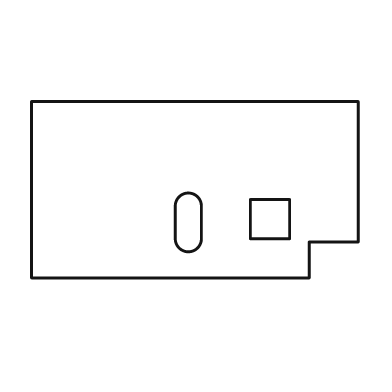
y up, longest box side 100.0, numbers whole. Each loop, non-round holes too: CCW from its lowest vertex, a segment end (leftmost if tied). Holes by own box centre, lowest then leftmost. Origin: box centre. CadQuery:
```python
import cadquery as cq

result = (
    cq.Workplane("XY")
    .moveTo(-50.0, -27.0)
    .lineTo(35.0, -27.0)
    .lineTo(35.0, -16.0)
    .lineTo(50.0, -16.0)
    .lineTo(50.0, 27.0)
    .lineTo(-50.0, 27.0)
    .close()
    .moveTo(-6.0, -15.0)
    .threePointArc((-2.0, -19.0), (2.0, -15.0))
    .lineTo(2.0, -5.0)
    .threePointArc((-2.0, -1.0), (-6.0, -5.0))
    .close()
    .moveTo(17.0, -15.0)
    .lineTo(29.0, -15.0)
    .lineTo(29.0, -3.0)
    .lineTo(17.0, -3.0)
    .close()
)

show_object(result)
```